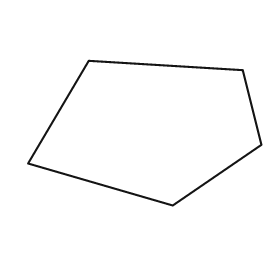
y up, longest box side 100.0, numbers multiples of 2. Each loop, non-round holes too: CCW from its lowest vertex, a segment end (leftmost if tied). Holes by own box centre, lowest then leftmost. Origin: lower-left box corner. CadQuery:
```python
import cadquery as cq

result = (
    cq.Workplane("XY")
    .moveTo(62.0, 0.0)
    .lineTo(100.0, 26.0)
    .lineTo(92.0, 58.0)
    .lineTo(26.0, 62.0)
    .lineTo(0.0, 18.0)
    .close()
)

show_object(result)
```